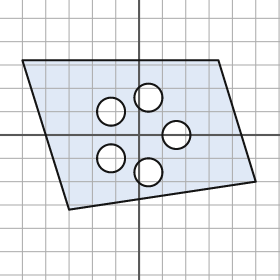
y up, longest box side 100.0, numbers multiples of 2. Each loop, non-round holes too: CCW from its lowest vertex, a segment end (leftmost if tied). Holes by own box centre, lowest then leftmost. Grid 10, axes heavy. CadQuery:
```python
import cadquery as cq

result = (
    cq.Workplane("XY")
    .moveTo(-30.0, -32.0)
    .lineTo(50.0, -20.0)
    .lineTo(34.0, 32.0)
    .lineTo(-50.0, 32.0)
    .close()
    .moveTo(4.0, -16.0)
    .circle(6.0)
    .moveTo(-12.0, -10.0)
    .circle(6.0)
    .moveTo(16.0, 0.0)
    .circle(6.0)
    .moveTo(-12.0, 10.0)
    .circle(6.0)
    .moveTo(4.0, 16.0)
    .circle(6.0)
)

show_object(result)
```